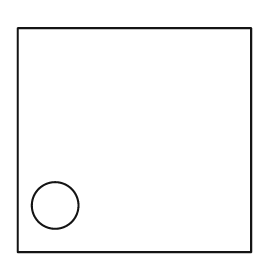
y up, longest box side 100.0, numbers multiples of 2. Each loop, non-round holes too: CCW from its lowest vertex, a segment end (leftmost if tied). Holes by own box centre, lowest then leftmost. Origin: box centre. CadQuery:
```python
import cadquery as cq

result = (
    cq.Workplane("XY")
    .moveTo(-50.0, -48.0)
    .lineTo(50.0, -48.0)
    .lineTo(50.0, 48.0)
    .lineTo(-50.0, 48.0)
    .close()
    .moveTo(-34.0, -28.0)
    .circle(10.0)
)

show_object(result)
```